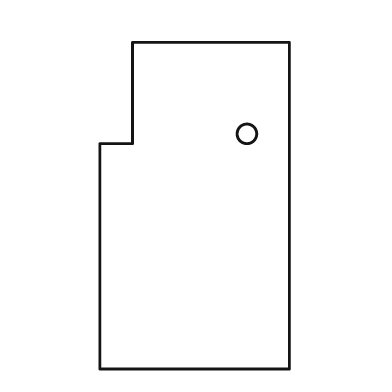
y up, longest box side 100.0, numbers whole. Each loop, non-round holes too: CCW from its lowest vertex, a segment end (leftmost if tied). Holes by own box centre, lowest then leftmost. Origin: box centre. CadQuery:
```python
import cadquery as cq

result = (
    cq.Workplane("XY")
    .moveTo(-29.0, -50.0)
    .lineTo(29.0, -50.0)
    .lineTo(29.0, 50.0)
    .lineTo(-19.0, 50.0)
    .lineTo(-19.0, 19.0)
    .lineTo(-29.0, 19.0)
    .close()
    .moveTo(16.0, 22.0)
    .circle(3.0)
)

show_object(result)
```